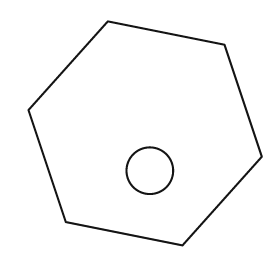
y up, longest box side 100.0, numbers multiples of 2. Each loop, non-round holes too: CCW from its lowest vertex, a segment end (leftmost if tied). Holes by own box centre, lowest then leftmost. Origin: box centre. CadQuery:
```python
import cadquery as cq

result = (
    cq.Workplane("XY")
    .moveTo(16.0, -48.0)
    .lineTo(50.0, -10.0)
    .lineTo(34.0, 38.0)
    .lineTo(-16.0, 48.0)
    .lineTo(-50.0, 10.0)
    .lineTo(-34.0, -38.0)
    .close()
    .moveTo(2.0, -16.0)
    .circle(10.0)
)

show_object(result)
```